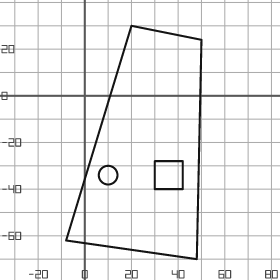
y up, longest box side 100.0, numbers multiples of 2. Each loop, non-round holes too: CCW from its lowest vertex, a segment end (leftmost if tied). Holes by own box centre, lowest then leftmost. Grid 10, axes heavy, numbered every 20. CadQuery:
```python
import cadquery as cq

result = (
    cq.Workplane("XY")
    .moveTo(48.0, -70.0)
    .lineTo(50.0, 24.0)
    .lineTo(20.0, 30.0)
    .lineTo(-8.0, -62.0)
    .close()
    .moveTo(10.0, -34.0)
    .circle(4.0)
    .moveTo(30.0, -40.0)
    .lineTo(42.0, -40.0)
    .lineTo(42.0, -28.0)
    .lineTo(30.0, -28.0)
    .close()
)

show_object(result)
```